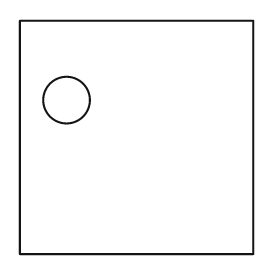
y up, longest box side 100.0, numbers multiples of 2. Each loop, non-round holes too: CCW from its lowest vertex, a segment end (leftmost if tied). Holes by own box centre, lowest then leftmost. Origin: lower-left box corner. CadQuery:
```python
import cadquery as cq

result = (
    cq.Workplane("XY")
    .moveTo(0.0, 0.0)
    .lineTo(100.0, 0.0)
    .lineTo(100.0, 100.0)
    .lineTo(0.0, 100.0)
    .close()
    .moveTo(20.0, 66.0)
    .circle(10.0)
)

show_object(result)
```